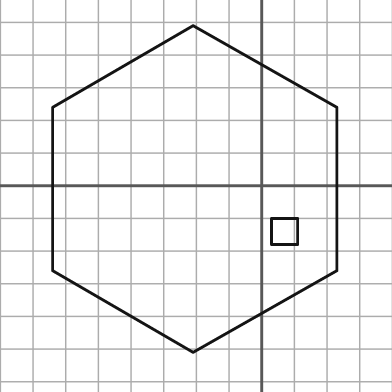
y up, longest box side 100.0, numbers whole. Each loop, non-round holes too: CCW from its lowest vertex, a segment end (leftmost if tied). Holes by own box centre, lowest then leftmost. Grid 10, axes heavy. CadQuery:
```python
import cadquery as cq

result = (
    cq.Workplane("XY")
    .moveTo(-21.0, -51.0)
    .lineTo(23.0, -26.0)
    .lineTo(23.0, 24.0)
    .lineTo(-21.0, 49.0)
    .lineTo(-64.0, 24.0)
    .lineTo(-64.0, -26.0)
    .close()
    .moveTo(3.0, -18.0)
    .lineTo(11.0, -18.0)
    .lineTo(11.0, -10.0)
    .lineTo(3.0, -10.0)
    .close()
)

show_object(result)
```